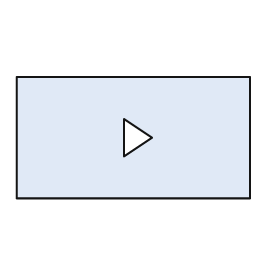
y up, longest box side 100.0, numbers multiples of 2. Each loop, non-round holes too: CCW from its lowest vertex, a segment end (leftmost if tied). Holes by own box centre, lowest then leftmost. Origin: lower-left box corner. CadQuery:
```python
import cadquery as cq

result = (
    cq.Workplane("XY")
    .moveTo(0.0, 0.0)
    .lineTo(100.0, 0.0)
    .lineTo(100.0, 52.0)
    .lineTo(0.0, 52.0)
    .close()
    .moveTo(46.0, 18.0)
    .lineTo(58.0, 26.0)
    .lineTo(46.0, 34.0)
    .close()
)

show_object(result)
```